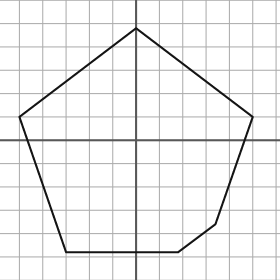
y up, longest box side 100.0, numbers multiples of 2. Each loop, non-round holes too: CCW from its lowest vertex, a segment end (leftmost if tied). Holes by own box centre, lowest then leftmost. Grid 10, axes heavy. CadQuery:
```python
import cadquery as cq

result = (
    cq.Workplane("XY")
    .moveTo(-30.0, -48.0)
    .lineTo(18.0, -48.0)
    .lineTo(34.0, -36.0)
    .lineTo(50.0, 10.0)
    .lineTo(0.0, 48.0)
    .lineTo(-50.0, 10.0)
    .close()
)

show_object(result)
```